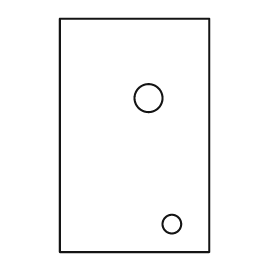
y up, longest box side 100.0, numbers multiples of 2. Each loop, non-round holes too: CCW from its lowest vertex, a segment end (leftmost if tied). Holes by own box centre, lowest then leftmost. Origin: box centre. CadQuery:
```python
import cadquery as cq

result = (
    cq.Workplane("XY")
    .moveTo(-32.0, -50.0)
    .lineTo(32.0, -50.0)
    .lineTo(32.0, 50.0)
    .lineTo(-32.0, 50.0)
    .close()
    .moveTo(16.0, -38.0)
    .circle(4.0)
    .moveTo(6.0, 16.0)
    .circle(6.0)
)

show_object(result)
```